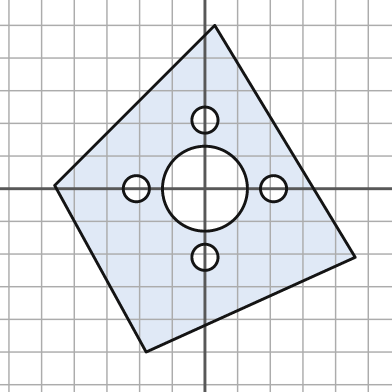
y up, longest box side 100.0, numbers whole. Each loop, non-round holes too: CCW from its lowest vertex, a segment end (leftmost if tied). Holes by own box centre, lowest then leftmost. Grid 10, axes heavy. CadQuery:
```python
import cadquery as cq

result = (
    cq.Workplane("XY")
    .moveTo(-18.0, -50.0)
    .lineTo(46.0, -21.0)
    .lineTo(3.0, 50.0)
    .lineTo(-46.0, 1.0)
    .close()
    .moveTo(0.0, -21.0)
    .circle(4.0)
    .moveTo(-21.0, 0.0)
    .circle(4.0)
    .moveTo(0.0, 0.0)
    .circle(13.0)
    .moveTo(21.0, 0.0)
    .circle(4.0)
    .moveTo(0.0, 21.0)
    .circle(4.0)
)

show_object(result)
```